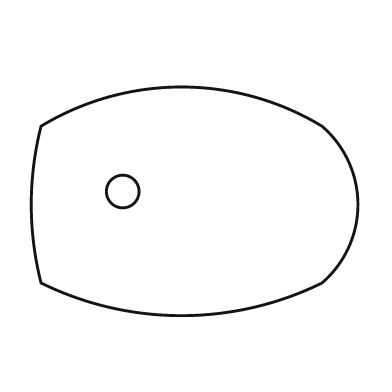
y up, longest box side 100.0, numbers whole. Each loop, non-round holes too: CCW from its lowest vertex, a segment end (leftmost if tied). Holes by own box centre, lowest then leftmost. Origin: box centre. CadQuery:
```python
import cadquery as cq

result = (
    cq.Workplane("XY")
    .moveTo(-47.0, -25.0)
    .threePointArc((-4.0, -35.0), (39.0, -25.0))
    .threePointArc((50.0, -1.0), (39.0, 23.0))
    .threePointArc((-4.0, 35.0), (-47.0, 23.0))
    .threePointArc((-50.0, -1.0), (-47.0, -25.0))
    .close()
    .moveTo(-22.0, 3.0)
    .circle(5.0)
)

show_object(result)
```